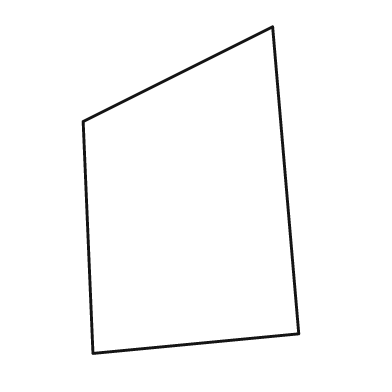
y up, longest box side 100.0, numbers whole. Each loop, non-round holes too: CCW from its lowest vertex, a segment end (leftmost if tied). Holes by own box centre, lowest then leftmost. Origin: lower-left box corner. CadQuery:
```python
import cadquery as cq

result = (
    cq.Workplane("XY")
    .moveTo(3.0, 0.0)
    .lineTo(66.0, 6.0)
    .lineTo(58.0, 100.0)
    .lineTo(0.0, 71.0)
    .close()
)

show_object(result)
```